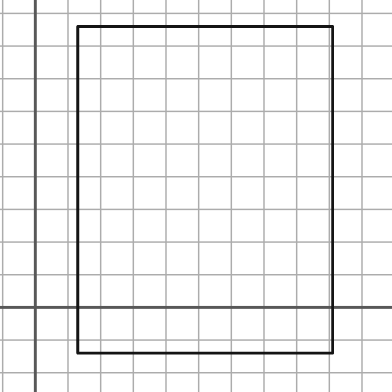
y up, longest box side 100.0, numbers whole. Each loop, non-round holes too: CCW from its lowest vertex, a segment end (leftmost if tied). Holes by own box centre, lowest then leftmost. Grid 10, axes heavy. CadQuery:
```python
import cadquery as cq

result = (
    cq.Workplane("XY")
    .moveTo(13.0, -14.0)
    .lineTo(91.0, -14.0)
    .lineTo(91.0, 86.0)
    .lineTo(13.0, 86.0)
    .close()
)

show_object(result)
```